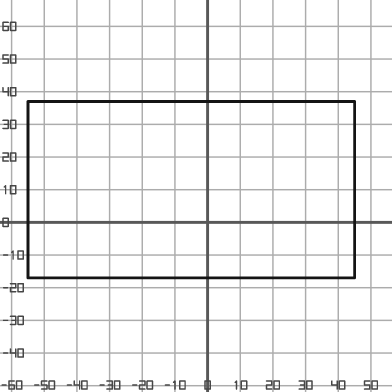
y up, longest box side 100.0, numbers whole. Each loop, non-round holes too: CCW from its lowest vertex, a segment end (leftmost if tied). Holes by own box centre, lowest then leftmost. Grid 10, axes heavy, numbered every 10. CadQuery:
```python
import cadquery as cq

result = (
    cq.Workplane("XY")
    .moveTo(-55.0, -17.0)
    .lineTo(45.0, -17.0)
    .lineTo(45.0, 37.0)
    .lineTo(-55.0, 37.0)
    .close()
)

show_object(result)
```